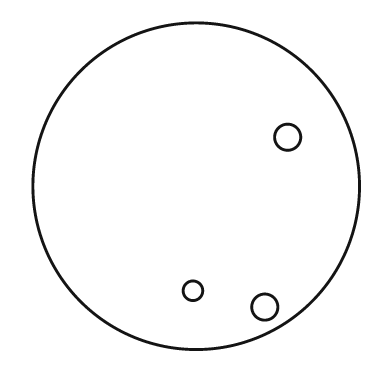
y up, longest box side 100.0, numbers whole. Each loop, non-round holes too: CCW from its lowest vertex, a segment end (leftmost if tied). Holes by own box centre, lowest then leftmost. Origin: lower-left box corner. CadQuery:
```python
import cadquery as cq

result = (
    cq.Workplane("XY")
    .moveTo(50.0, 50.0)
    .circle(50.0)
    .moveTo(71.0, 13.0)
    .circle(4.0)
    .moveTo(49.0, 18.0)
    .circle(3.0)
    .moveTo(78.0, 65.0)
    .circle(4.0)
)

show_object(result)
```